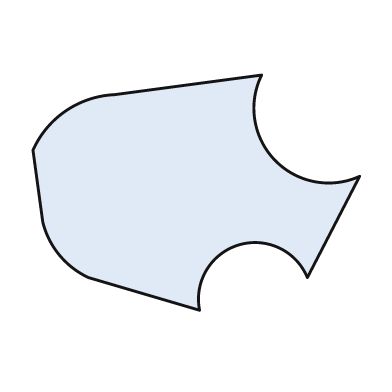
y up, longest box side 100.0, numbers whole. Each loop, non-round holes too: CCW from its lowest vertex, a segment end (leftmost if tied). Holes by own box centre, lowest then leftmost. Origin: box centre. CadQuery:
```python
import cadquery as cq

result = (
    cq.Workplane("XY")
    .moveTo(1.0, -36.0)
    .threePointArc((13.0, -16.0), (34.0, -26.0))
    .lineTo(50.0, 5.0)
    .threePointArc((24.0, 10.0), (20.0, 36.0))
    .lineTo(-25.0, 30.0)
    .threePointArc((-40.0, 25.0), (-50.0, 13.0))
    .lineTo(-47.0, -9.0)
    .threePointArc((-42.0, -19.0), (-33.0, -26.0))
    .close()
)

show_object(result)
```